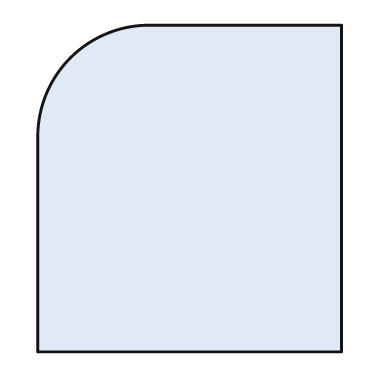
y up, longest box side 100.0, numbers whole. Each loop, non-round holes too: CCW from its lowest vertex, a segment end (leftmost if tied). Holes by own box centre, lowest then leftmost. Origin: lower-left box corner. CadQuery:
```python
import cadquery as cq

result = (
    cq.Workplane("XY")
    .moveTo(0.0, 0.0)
    .lineTo(93.0, 0.0)
    .lineTo(93.0, 100.0)
    .lineTo(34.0, 100.0)
    .threePointArc((10.0, 90.0), (0.0, 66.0))
    .close()
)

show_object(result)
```